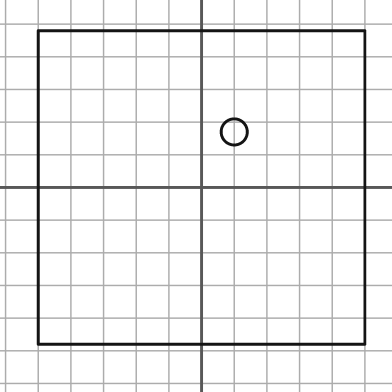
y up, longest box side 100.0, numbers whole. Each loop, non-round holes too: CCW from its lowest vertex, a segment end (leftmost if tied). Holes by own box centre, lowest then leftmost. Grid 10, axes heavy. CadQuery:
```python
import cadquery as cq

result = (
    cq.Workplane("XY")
    .moveTo(-50.0, -48.0)
    .lineTo(50.0, -48.0)
    .lineTo(50.0, 48.0)
    .lineTo(-50.0, 48.0)
    .close()
    .moveTo(10.0, 17.0)
    .circle(4.0)
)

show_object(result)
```